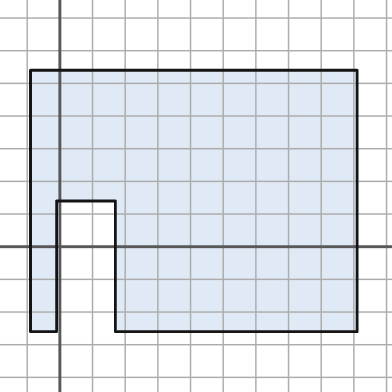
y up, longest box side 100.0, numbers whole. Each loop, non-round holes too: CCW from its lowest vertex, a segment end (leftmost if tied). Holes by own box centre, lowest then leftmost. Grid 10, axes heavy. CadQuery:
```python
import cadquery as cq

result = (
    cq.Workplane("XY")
    .moveTo(-9.0, -26.0)
    .lineTo(-1.0, -26.0)
    .lineTo(-1.0, 14.0)
    .lineTo(17.0, 14.0)
    .lineTo(17.0, -26.0)
    .lineTo(91.0, -26.0)
    .lineTo(91.0, 54.0)
    .lineTo(-9.0, 54.0)
    .close()
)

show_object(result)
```